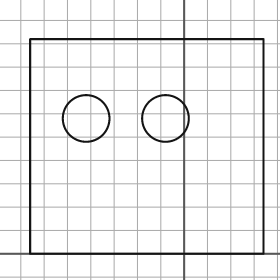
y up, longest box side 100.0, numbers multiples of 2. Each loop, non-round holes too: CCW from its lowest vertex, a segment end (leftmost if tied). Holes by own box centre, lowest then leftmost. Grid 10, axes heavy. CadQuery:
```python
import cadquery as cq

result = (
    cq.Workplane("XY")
    .moveTo(-66.0, 0.0)
    .lineTo(34.0, 0.0)
    .lineTo(34.0, 92.0)
    .lineTo(-66.0, 92.0)
    .close()
    .moveTo(-42.0, 58.0)
    .circle(10.0)
    .moveTo(-8.0, 58.0)
    .circle(10.0)
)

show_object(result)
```